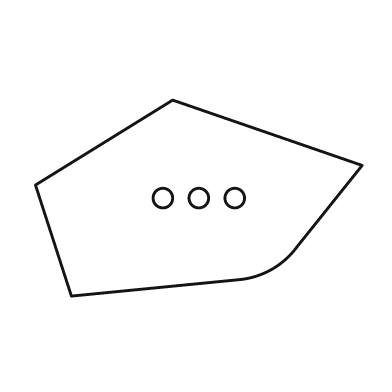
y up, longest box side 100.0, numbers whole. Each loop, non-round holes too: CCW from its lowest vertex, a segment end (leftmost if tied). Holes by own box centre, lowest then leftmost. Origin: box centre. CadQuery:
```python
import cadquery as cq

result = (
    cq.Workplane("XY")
    .moveTo(-39.0, -30.0)
    .lineTo(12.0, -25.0)
    .threePointArc((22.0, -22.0), (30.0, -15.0))
    .lineTo(50.0, 10.0)
    .lineTo(-8.0, 30.0)
    .lineTo(-50.0, 4.0)
    .close()
    .moveTo(-11.0, 0.0)
    .circle(3.0)
    .moveTo(0.0, 0.0)
    .circle(3.0)
    .moveTo(11.0, 0.0)
    .circle(3.0)
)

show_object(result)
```